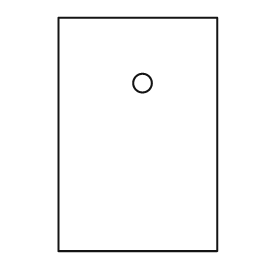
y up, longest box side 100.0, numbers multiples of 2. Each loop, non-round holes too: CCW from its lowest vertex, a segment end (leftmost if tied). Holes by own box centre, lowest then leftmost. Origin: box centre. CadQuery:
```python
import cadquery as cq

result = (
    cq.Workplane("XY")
    .moveTo(-34.0, -50.0)
    .lineTo(34.0, -50.0)
    .lineTo(34.0, 50.0)
    .lineTo(-34.0, 50.0)
    .close()
    .moveTo(2.0, 22.0)
    .circle(4.0)
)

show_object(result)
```